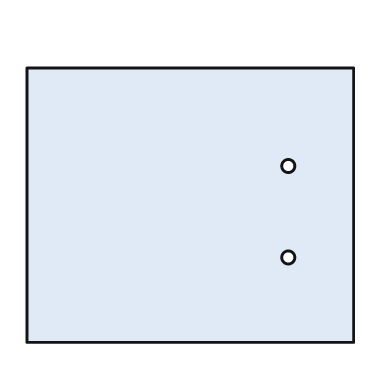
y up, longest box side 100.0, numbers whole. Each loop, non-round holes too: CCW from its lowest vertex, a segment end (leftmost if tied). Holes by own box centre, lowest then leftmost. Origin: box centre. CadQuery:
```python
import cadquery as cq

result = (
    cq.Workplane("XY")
    .moveTo(-50.0, -42.0)
    .lineTo(50.0, -42.0)
    .lineTo(50.0, 42.0)
    .lineTo(-50.0, 42.0)
    .close()
    .moveTo(30.0, -16.0)
    .circle(2.0)
    .moveTo(30.0, 12.0)
    .circle(2.0)
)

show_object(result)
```